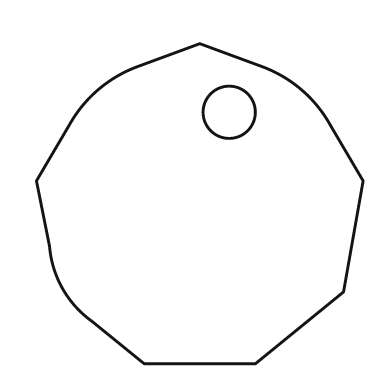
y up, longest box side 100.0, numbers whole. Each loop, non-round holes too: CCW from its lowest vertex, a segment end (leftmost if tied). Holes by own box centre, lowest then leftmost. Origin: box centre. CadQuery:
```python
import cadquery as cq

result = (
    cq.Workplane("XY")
    .moveTo(-17.0, -49.0)
    .lineTo(17.0, -49.0)
    .lineTo(44.0, -27.0)
    .lineTo(50.0, 7.0)
    .lineTo(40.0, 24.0)
    .threePointArc((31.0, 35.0), (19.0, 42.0))
    .lineTo(0.0, 49.0)
    .lineTo(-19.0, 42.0)
    .threePointArc((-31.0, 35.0), (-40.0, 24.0))
    .lineTo(-50.0, 7.0)
    .lineTo(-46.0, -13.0)
    .threePointArc((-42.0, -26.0), (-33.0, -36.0))
    .close()
    .moveTo(9.0, 28.0)
    .circle(8.0)
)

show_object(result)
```